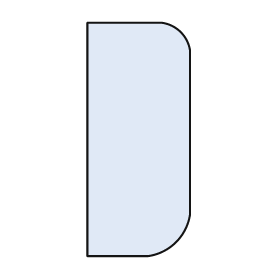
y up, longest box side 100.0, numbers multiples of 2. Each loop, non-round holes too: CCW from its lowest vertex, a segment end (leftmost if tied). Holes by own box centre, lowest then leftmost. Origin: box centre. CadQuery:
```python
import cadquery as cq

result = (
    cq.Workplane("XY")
    .moveTo(-22.0, -50.0)
    .lineTo(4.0, -50.0)
    .threePointArc((16.0, -44.0), (22.0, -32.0))
    .lineTo(22.0, 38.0)
    .threePointArc((18.0, 46.0), (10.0, 50.0))
    .lineTo(-22.0, 50.0)
    .close()
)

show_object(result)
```